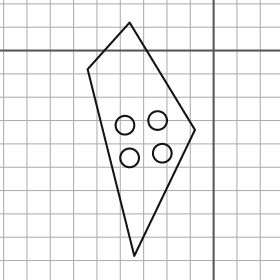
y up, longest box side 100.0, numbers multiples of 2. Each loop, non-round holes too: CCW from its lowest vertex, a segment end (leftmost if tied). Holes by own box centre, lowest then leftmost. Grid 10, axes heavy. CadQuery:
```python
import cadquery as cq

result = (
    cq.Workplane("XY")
    .moveTo(-34.0, -88.0)
    .lineTo(-8.0, -34.0)
    .lineTo(-36.0, 12.0)
    .lineTo(-54.0, -8.0)
    .close()
    .moveTo(-36.0, -46.0)
    .circle(4.0)
    .moveTo(-22.0, -44.0)
    .circle(4.0)
    .moveTo(-38.0, -32.0)
    .circle(4.0)
    .moveTo(-24.0, -30.0)
    .circle(4.0)
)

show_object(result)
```